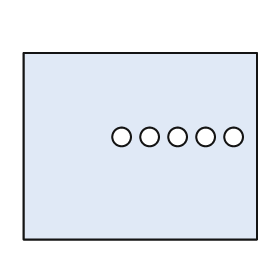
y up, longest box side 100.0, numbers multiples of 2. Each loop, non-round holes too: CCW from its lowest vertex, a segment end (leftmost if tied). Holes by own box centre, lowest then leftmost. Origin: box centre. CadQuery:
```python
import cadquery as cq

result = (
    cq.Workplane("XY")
    .moveTo(-50.0, -40.0)
    .lineTo(50.0, -40.0)
    .lineTo(50.0, 40.0)
    .lineTo(-50.0, 40.0)
    .close()
    .moveTo(-8.0, 4.0)
    .circle(4.0)
    .moveTo(4.0, 4.0)
    .circle(4.0)
    .moveTo(16.0, 4.0)
    .circle(4.0)
    .moveTo(28.0, 4.0)
    .circle(4.0)
    .moveTo(40.0, 4.0)
    .circle(4.0)
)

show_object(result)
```